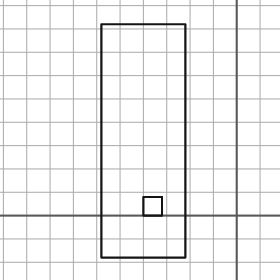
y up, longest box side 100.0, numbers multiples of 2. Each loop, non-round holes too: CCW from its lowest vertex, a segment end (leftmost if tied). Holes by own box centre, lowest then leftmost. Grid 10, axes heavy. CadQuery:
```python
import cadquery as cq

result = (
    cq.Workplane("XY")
    .moveTo(-58.0, -18.0)
    .lineTo(-22.0, -18.0)
    .lineTo(-22.0, 82.0)
    .lineTo(-58.0, 82.0)
    .close()
    .moveTo(-40.0, 0.0)
    .lineTo(-32.0, 0.0)
    .lineTo(-32.0, 8.0)
    .lineTo(-40.0, 8.0)
    .close()
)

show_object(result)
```